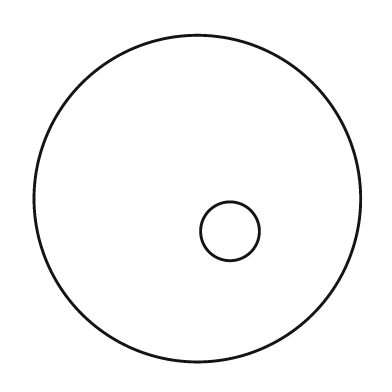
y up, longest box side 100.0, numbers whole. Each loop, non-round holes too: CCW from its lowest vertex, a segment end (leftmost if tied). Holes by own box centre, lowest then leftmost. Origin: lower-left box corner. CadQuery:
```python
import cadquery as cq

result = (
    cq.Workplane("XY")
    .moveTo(50.0, 50.0)
    .circle(50.0)
    .moveTo(60.0, 40.0)
    .circle(9.0)
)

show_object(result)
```